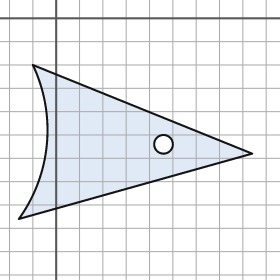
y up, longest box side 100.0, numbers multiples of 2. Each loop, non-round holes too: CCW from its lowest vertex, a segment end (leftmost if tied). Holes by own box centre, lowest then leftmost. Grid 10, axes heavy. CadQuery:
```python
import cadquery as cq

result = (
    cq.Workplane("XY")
    .moveTo(-16.0, -86.0)
    .lineTo(84.0, -58.0)
    .lineTo(-10.0, -20.0)
    .threePointArc((-4.0, -54.0), (-16.0, -86.0))
    .close()
    .moveTo(46.0, -54.0)
    .circle(4.0)
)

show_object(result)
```